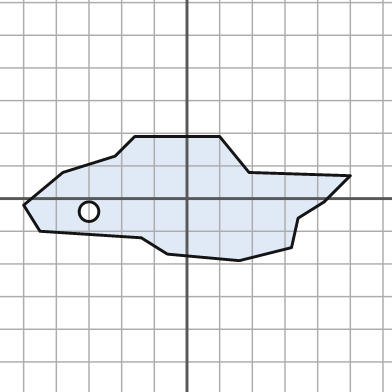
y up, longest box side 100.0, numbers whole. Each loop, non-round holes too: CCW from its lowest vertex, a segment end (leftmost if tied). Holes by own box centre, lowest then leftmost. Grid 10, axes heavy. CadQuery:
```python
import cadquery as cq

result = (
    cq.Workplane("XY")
    .moveTo(16.0, -19.0)
    .lineTo(32.0, -15.0)
    .lineTo(34.0, -6.0)
    .lineTo(42.0, -1.0)
    .lineTo(50.0, 7.0)
    .lineTo(19.0, 8.0)
    .lineTo(10.0, 19.0)
    .lineTo(-16.0, 19.0)
    .lineTo(-22.0, 13.0)
    .lineTo(-38.0, 8.0)
    .lineTo(-50.0, -2.0)
    .lineTo(-45.0, -10.0)
    .lineTo(-14.0, -12.0)
    .lineTo(-6.0, -17.0)
    .close()
    .moveTo(-30.0, -4.0)
    .circle(3.0)
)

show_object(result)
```